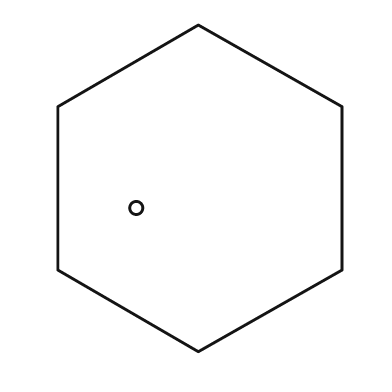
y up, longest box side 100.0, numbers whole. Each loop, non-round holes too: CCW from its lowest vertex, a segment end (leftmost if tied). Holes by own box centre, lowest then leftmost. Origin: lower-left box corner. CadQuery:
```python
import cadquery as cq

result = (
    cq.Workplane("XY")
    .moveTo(43.0, 0.0)
    .lineTo(87.0, 25.0)
    .lineTo(87.0, 75.0)
    .lineTo(43.0, 100.0)
    .lineTo(0.0, 75.0)
    .lineTo(0.0, 25.0)
    .close()
    .moveTo(24.0, 44.0)
    .circle(2.0)
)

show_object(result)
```